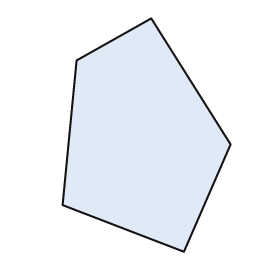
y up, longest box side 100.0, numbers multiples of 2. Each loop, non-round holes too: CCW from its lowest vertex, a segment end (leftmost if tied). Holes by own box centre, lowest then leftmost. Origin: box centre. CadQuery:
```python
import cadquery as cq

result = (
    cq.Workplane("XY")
    .moveTo(16.0, -50.0)
    .lineTo(36.0, -4.0)
    .lineTo(2.0, 50.0)
    .lineTo(-30.0, 32.0)
    .lineTo(-36.0, -30.0)
    .close()
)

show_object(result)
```